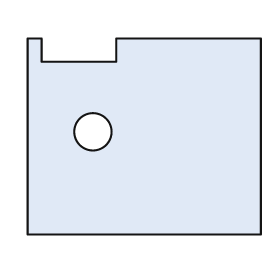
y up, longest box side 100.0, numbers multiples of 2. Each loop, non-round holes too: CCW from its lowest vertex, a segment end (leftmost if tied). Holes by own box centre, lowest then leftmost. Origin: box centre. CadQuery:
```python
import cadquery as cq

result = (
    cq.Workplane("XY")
    .moveTo(-50.0, -42.0)
    .lineTo(50.0, -42.0)
    .lineTo(50.0, 42.0)
    .lineTo(-12.0, 42.0)
    .lineTo(-12.0, 32.0)
    .lineTo(-44.0, 32.0)
    .lineTo(-44.0, 42.0)
    .lineTo(-50.0, 42.0)
    .close()
    .moveTo(-22.0, 2.0)
    .circle(8.0)
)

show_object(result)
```